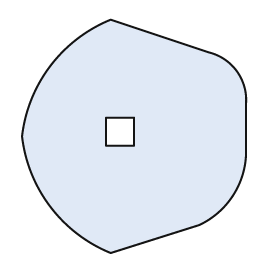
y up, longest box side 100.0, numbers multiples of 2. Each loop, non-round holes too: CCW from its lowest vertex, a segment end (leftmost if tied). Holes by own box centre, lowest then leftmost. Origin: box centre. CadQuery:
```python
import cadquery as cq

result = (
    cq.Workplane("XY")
    .moveTo(-10.0, -50.0)
    .lineTo(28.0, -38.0)
    .threePointArc((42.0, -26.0), (48.0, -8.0))
    .lineTo(48.0, 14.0)
    .threePointArc((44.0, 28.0), (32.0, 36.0))
    .lineTo(-10.0, 50.0)
    .threePointArc((-36.0, 30.0), (-48.0, 0.0))
    .threePointArc((-36.0, -30.0), (-10.0, -50.0))
    .close()
    .moveTo(-12.0, -4.0)
    .lineTo(0.0, -4.0)
    .lineTo(0.0, 8.0)
    .lineTo(-12.0, 8.0)
    .close()
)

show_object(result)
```